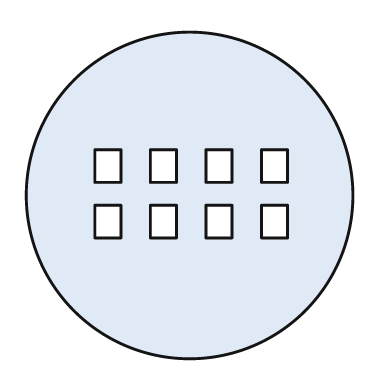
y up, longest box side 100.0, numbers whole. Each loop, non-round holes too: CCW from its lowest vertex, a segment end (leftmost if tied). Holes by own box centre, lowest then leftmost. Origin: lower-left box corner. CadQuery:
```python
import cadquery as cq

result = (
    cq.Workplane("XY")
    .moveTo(50.0, 50.0)
    .circle(50.0)
    .moveTo(21.0, 37.0)
    .lineTo(29.0, 37.0)
    .lineTo(29.0, 47.0)
    .lineTo(21.0, 47.0)
    .close()
    .moveTo(38.0, 37.0)
    .lineTo(46.0, 37.0)
    .lineTo(46.0, 47.0)
    .lineTo(38.0, 47.0)
    .close()
    .moveTo(55.0, 37.0)
    .lineTo(63.0, 37.0)
    .lineTo(63.0, 47.0)
    .lineTo(55.0, 47.0)
    .close()
    .moveTo(72.0, 37.0)
    .lineTo(80.0, 37.0)
    .lineTo(80.0, 47.0)
    .lineTo(72.0, 47.0)
    .close()
    .moveTo(21.0, 54.0)
    .lineTo(29.0, 54.0)
    .lineTo(29.0, 64.0)
    .lineTo(21.0, 64.0)
    .close()
    .moveTo(38.0, 54.0)
    .lineTo(46.0, 54.0)
    .lineTo(46.0, 64.0)
    .lineTo(38.0, 64.0)
    .close()
    .moveTo(55.0, 54.0)
    .lineTo(63.0, 54.0)
    .lineTo(63.0, 64.0)
    .lineTo(55.0, 64.0)
    .close()
    .moveTo(72.0, 54.0)
    .lineTo(80.0, 54.0)
    .lineTo(80.0, 64.0)
    .lineTo(72.0, 64.0)
    .close()
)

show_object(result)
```